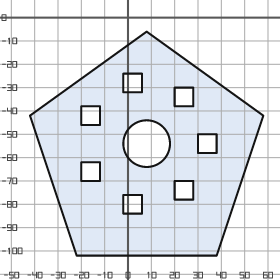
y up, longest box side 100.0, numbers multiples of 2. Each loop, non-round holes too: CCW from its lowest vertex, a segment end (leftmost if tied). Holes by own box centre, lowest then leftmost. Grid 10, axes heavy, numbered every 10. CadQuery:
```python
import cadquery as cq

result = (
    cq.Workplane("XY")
    .moveTo(-22.0, -102.0)
    .lineTo(38.0, -102.0)
    .lineTo(58.0, -42.0)
    .lineTo(8.0, -6.0)
    .lineTo(-42.0, -42.0)
    .close()
    .moveTo(-2.0, -84.0)
    .lineTo(6.0, -84.0)
    .lineTo(6.0, -76.0)
    .lineTo(-2.0, -76.0)
    .close()
    .moveTo(20.0, -78.0)
    .lineTo(28.0, -78.0)
    .lineTo(28.0, -70.0)
    .lineTo(20.0, -70.0)
    .close()
    .moveTo(-20.0, -70.0)
    .lineTo(-12.0, -70.0)
    .lineTo(-12.0, -62.0)
    .lineTo(-20.0, -62.0)
    .close()
    .moveTo(8.0, -54.0)
    .circle(10.0)
    .moveTo(30.0, -58.0)
    .lineTo(38.0, -58.0)
    .lineTo(38.0, -50.0)
    .lineTo(30.0, -50.0)
    .close()
    .moveTo(-20.0, -46.0)
    .lineTo(-12.0, -46.0)
    .lineTo(-12.0, -38.0)
    .lineTo(-20.0, -38.0)
    .close()
    .moveTo(20.0, -38.0)
    .lineTo(28.0, -38.0)
    .lineTo(28.0, -30.0)
    .lineTo(20.0, -30.0)
    .close()
    .moveTo(-2.0, -32.0)
    .lineTo(6.0, -32.0)
    .lineTo(6.0, -24.0)
    .lineTo(-2.0, -24.0)
    .close()
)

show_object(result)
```